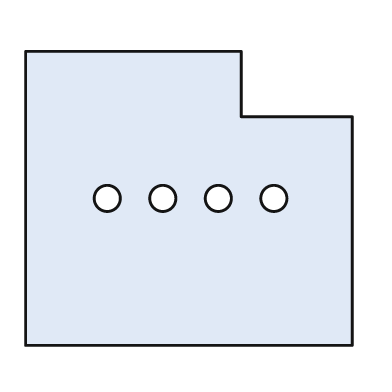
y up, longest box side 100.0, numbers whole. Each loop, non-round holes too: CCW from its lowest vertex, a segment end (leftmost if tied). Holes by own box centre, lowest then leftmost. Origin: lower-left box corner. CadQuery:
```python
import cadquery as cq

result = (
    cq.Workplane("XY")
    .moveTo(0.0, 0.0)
    .lineTo(100.0, 0.0)
    .lineTo(100.0, 70.0)
    .lineTo(66.0, 70.0)
    .lineTo(66.0, 90.0)
    .lineTo(0.0, 90.0)
    .close()
    .moveTo(25.0, 45.0)
    .circle(4.0)
    .moveTo(42.0, 45.0)
    .circle(4.0)
    .moveTo(59.0, 45.0)
    .circle(4.0)
    .moveTo(76.0, 45.0)
    .circle(4.0)
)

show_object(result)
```